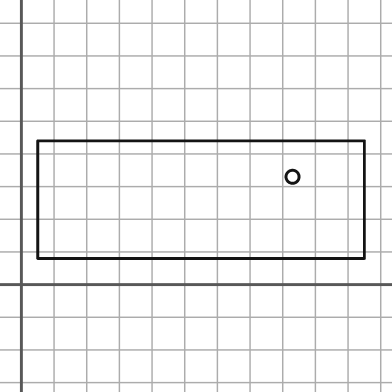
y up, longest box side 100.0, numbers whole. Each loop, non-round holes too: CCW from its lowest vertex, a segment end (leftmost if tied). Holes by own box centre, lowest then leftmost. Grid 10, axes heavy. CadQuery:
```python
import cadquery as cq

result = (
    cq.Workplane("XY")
    .moveTo(5.0, 8.0)
    .lineTo(105.0, 8.0)
    .lineTo(105.0, 44.0)
    .lineTo(5.0, 44.0)
    .close()
    .moveTo(83.0, 33.0)
    .circle(2.0)
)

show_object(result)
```